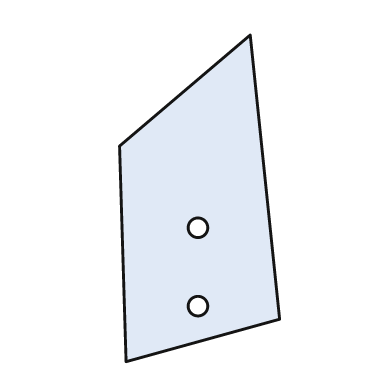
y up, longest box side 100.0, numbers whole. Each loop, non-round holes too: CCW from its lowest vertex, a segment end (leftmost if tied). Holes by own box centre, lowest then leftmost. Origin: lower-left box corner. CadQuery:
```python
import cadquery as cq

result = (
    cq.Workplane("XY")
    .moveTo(2.0, 0.0)
    .lineTo(49.0, 13.0)
    .lineTo(40.0, 100.0)
    .lineTo(0.0, 66.0)
    .close()
    .moveTo(24.0, 17.0)
    .circle(3.0)
    .moveTo(24.0, 41.0)
    .circle(3.0)
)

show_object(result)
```